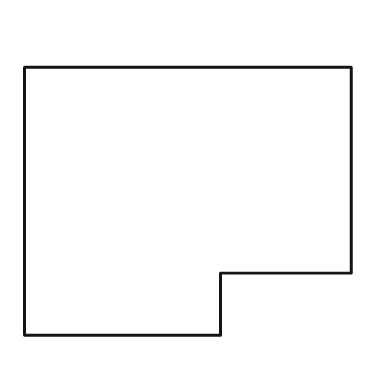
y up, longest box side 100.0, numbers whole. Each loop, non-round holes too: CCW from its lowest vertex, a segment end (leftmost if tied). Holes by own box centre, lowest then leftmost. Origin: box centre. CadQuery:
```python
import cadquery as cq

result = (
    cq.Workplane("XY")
    .moveTo(-50.0, -41.0)
    .lineTo(10.0, -41.0)
    .lineTo(10.0, -22.0)
    .lineTo(50.0, -22.0)
    .lineTo(50.0, 41.0)
    .lineTo(-50.0, 41.0)
    .close()
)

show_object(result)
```